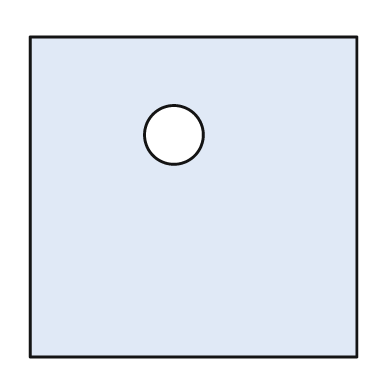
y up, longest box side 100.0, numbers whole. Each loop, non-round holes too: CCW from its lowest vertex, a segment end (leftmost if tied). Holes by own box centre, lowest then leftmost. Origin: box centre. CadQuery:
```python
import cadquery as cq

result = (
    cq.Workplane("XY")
    .moveTo(-50.0, -49.0)
    .lineTo(50.0, -49.0)
    .lineTo(50.0, 49.0)
    .lineTo(-50.0, 49.0)
    .close()
    .moveTo(-6.0, 19.0)
    .circle(9.0)
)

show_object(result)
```